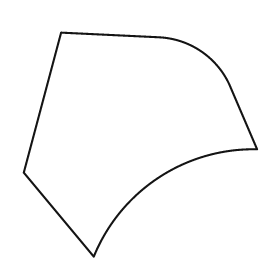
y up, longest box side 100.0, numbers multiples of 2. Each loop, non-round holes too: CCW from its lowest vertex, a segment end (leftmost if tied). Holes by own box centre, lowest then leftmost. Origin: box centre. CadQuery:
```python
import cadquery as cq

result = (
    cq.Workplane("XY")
    .moveTo(-20.0, -48.0)
    .threePointArc((8.0, -14.0), (50.0, -2.0))
    .lineTo(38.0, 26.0)
    .threePointArc((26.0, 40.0), (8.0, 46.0))
    .lineTo(-34.0, 48.0)
    .lineTo(-50.0, -12.0)
    .close()
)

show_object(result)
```